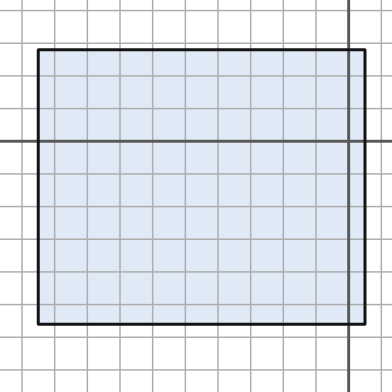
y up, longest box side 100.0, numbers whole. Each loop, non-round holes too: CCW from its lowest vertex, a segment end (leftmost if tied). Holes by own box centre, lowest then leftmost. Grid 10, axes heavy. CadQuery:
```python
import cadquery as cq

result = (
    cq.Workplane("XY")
    .moveTo(-95.0, -56.0)
    .lineTo(5.0, -56.0)
    .lineTo(5.0, 28.0)
    .lineTo(-95.0, 28.0)
    .close()
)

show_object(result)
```